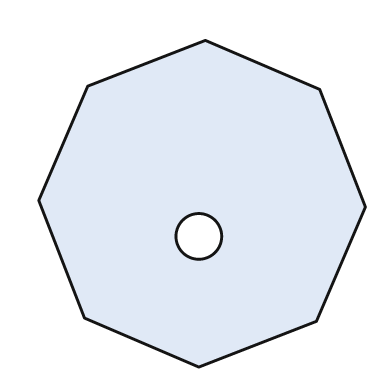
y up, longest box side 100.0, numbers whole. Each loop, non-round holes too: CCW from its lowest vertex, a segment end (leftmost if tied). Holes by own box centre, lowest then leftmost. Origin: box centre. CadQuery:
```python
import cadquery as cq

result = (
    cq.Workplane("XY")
    .moveTo(-1.0, -50.0)
    .lineTo(35.0, -36.0)
    .lineTo(50.0, -1.0)
    .lineTo(36.0, 35.0)
    .lineTo(1.0, 50.0)
    .lineTo(-35.0, 36.0)
    .lineTo(-50.0, 1.0)
    .lineTo(-36.0, -35.0)
    .close()
    .moveTo(-1.0, -10.0)
    .circle(7.0)
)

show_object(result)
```